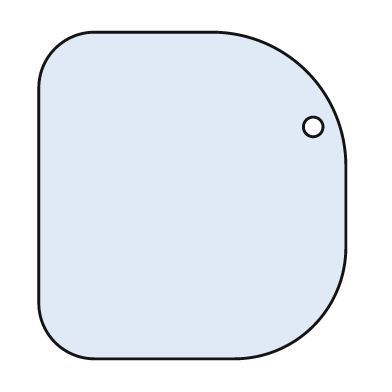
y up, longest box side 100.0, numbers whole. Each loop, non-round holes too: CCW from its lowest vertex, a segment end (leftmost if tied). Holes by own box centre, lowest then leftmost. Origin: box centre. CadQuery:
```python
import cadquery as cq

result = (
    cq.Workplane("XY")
    .moveTo(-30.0, -50.0)
    .lineTo(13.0, -50.0)
    .threePointArc((37.0, -40.0), (47.0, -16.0))
    .lineTo(47.0, 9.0)
    .threePointArc((35.0, 38.0), (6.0, 50.0))
    .lineTo(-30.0, 50.0)
    .threePointArc((-42.0, 45.0), (-47.0, 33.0))
    .lineTo(-47.0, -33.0)
    .threePointArc((-42.0, -45.0), (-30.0, -50.0))
    .close()
    .moveTo(37.0, 21.0)
    .circle(3.0)
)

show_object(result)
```